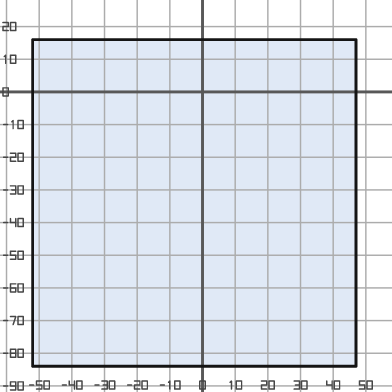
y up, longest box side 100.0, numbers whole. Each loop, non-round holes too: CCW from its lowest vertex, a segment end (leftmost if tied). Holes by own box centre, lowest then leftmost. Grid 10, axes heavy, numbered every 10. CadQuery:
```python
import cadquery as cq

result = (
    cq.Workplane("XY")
    .moveTo(-52.0, -84.0)
    .lineTo(47.0, -84.0)
    .lineTo(47.0, 16.0)
    .lineTo(-52.0, 16.0)
    .close()
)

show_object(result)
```